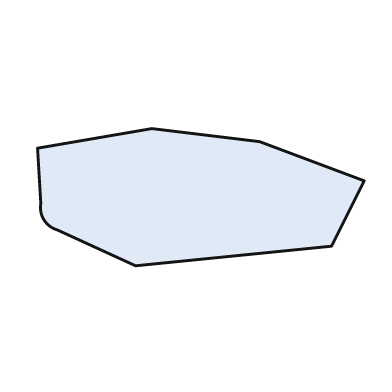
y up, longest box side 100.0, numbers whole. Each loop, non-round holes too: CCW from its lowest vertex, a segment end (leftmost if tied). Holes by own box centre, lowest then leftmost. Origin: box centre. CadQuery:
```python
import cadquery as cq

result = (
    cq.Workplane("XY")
    .moveTo(-20.0, -21.0)
    .lineTo(40.0, -15.0)
    .lineTo(50.0, 5.0)
    .lineTo(18.0, 17.0)
    .lineTo(-15.0, 21.0)
    .lineTo(-50.0, 15.0)
    .lineTo(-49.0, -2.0)
    .threePointArc((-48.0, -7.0), (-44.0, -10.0))
    .close()
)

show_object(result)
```